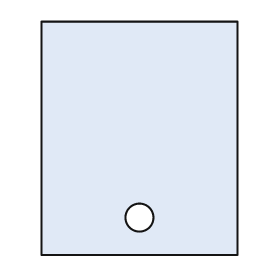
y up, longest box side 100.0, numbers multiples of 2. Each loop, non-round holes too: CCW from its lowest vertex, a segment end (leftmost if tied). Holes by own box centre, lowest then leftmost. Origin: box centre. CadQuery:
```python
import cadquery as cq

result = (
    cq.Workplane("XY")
    .moveTo(-42.0, -50.0)
    .lineTo(42.0, -50.0)
    .lineTo(42.0, 50.0)
    .lineTo(-42.0, 50.0)
    .close()
    .moveTo(0.0, -34.0)
    .circle(6.0)
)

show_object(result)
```